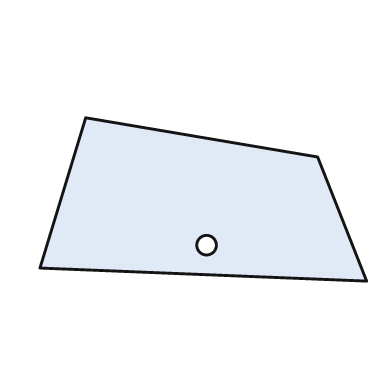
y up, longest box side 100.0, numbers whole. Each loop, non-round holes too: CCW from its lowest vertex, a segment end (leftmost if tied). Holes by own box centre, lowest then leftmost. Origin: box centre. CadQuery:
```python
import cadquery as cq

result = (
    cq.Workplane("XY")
    .moveTo(50.0, -25.0)
    .lineTo(35.0, 13.0)
    .lineTo(-36.0, 25.0)
    .lineTo(-50.0, -21.0)
    .close()
    .moveTo(1.0, -14.0)
    .circle(3.0)
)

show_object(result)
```